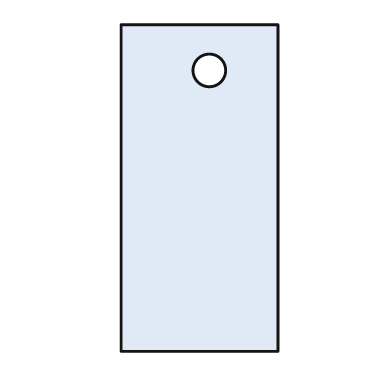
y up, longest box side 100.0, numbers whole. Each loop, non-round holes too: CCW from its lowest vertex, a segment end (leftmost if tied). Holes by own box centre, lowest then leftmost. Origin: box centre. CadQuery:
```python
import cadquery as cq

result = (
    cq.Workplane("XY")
    .moveTo(-24.0, -50.0)
    .lineTo(24.0, -50.0)
    .lineTo(24.0, 50.0)
    .lineTo(-24.0, 50.0)
    .close()
    .moveTo(3.0, 36.0)
    .circle(5.0)
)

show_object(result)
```